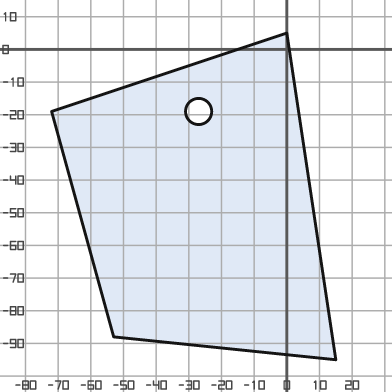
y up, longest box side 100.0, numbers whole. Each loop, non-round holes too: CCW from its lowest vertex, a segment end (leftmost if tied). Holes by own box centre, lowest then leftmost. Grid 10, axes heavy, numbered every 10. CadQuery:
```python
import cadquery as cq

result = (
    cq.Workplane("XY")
    .moveTo(15.0, -95.0)
    .lineTo(0.0, 5.0)
    .lineTo(-72.0, -19.0)
    .lineTo(-53.0, -88.0)
    .close()
    .moveTo(-27.0, -19.0)
    .circle(4.0)
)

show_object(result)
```